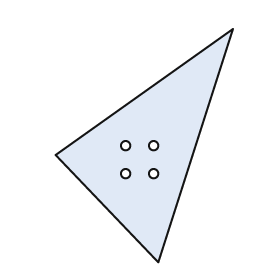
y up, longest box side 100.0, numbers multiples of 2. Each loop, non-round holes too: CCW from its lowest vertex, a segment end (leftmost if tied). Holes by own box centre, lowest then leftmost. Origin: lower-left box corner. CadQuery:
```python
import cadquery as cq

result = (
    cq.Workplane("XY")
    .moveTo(44.0, 0.0)
    .lineTo(76.0, 100.0)
    .lineTo(0.0, 46.0)
    .close()
    .moveTo(30.0, 38.0)
    .circle(2.0)
    .moveTo(42.0, 38.0)
    .circle(2.0)
    .moveTo(30.0, 50.0)
    .circle(2.0)
    .moveTo(42.0, 50.0)
    .circle(2.0)
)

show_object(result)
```